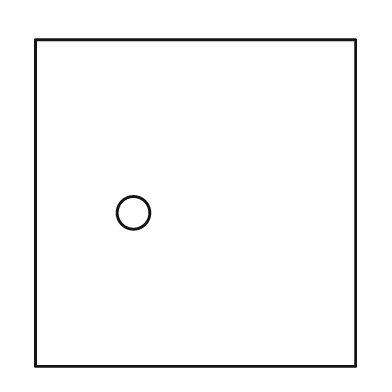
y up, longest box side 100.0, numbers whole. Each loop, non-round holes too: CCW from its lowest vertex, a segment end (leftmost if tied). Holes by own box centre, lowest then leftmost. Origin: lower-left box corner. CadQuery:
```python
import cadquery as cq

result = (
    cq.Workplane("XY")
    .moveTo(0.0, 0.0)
    .lineTo(98.0, 0.0)
    .lineTo(98.0, 100.0)
    .lineTo(0.0, 100.0)
    .close()
    .moveTo(30.0, 47.0)
    .circle(5.0)
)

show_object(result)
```